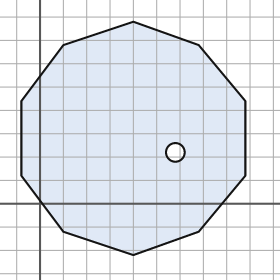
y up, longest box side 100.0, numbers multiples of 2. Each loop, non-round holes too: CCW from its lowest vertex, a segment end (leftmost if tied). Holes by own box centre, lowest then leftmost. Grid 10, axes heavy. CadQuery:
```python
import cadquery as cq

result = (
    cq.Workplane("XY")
    .moveTo(40.0, -22.0)
    .lineTo(68.0, -12.0)
    .lineTo(88.0, 12.0)
    .lineTo(88.0, 44.0)
    .lineTo(68.0, 68.0)
    .lineTo(40.0, 78.0)
    .lineTo(10.0, 68.0)
    .lineTo(-8.0, 44.0)
    .lineTo(-8.0, 12.0)
    .lineTo(10.0, -12.0)
    .close()
    .moveTo(58.0, 22.0)
    .circle(4.0)
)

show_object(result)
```